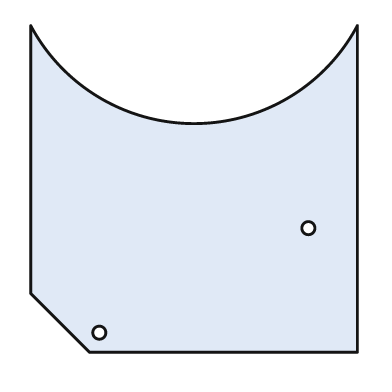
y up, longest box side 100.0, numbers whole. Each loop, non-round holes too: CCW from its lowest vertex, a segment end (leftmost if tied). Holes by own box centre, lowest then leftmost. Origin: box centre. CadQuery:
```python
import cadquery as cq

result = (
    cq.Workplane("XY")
    .moveTo(-32.0, -50.0)
    .lineTo(50.0, -50.0)
    .lineTo(50.0, 50.0)
    .threePointArc((0.0, 20.0), (-50.0, 50.0))
    .lineTo(-50.0, -32.0)
    .close()
    .moveTo(-29.0, -44.0)
    .circle(2.0)
    .moveTo(35.0, -12.0)
    .circle(2.0)
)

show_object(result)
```